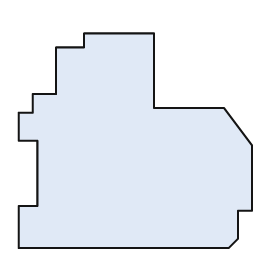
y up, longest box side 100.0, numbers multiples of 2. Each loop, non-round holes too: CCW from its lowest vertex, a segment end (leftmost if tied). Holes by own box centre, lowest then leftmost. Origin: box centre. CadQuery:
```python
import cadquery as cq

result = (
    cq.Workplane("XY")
    .moveTo(-50.0, -46.0)
    .lineTo(40.0, -46.0)
    .lineTo(44.0, -42.0)
    .lineTo(44.0, -30.0)
    .lineTo(50.0, -30.0)
    .lineTo(50.0, -2.0)
    .lineTo(38.0, 14.0)
    .lineTo(8.0, 14.0)
    .lineTo(8.0, 46.0)
    .lineTo(-22.0, 46.0)
    .lineTo(-22.0, 40.0)
    .lineTo(-34.0, 40.0)
    .lineTo(-34.0, 20.0)
    .lineTo(-44.0, 20.0)
    .lineTo(-44.0, 12.0)
    .lineTo(-50.0, 12.0)
    .lineTo(-50.0, 0.0)
    .lineTo(-42.0, 0.0)
    .lineTo(-42.0, -28.0)
    .lineTo(-50.0, -28.0)
    .close()
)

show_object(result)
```